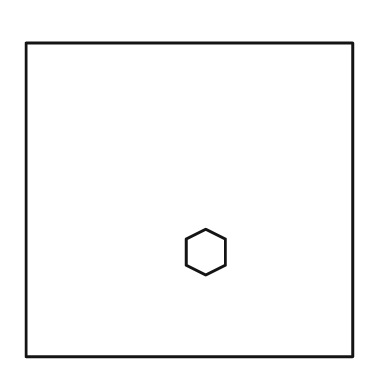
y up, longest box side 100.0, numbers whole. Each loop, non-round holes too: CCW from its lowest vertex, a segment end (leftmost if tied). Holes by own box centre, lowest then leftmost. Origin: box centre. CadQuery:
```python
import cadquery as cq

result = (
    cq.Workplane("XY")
    .moveTo(-50.0, -48.0)
    .lineTo(50.0, -48.0)
    .lineTo(50.0, 48.0)
    .lineTo(-50.0, 48.0)
    .close()
    .moveTo(5.0, -23.0)
    .lineTo(11.0, -20.0)
    .lineTo(11.0, -12.0)
    .lineTo(5.0, -9.0)
    .lineTo(-1.0, -12.0)
    .lineTo(-1.0, -20.0)
    .close()
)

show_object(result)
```